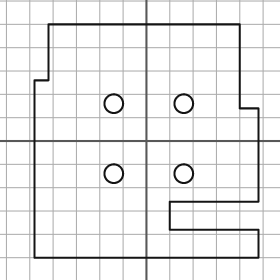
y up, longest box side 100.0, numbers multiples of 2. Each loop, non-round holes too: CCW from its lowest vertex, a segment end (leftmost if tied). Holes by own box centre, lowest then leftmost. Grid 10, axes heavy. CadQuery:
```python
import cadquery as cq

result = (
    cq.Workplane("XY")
    .moveTo(-48.0, -50.0)
    .lineTo(48.0, -50.0)
    .lineTo(48.0, -38.0)
    .lineTo(10.0, -38.0)
    .lineTo(10.0, -26.0)
    .lineTo(48.0, -26.0)
    .lineTo(48.0, 14.0)
    .lineTo(40.0, 14.0)
    .lineTo(40.0, 50.0)
    .lineTo(-42.0, 50.0)
    .lineTo(-42.0, 26.0)
    .lineTo(-48.0, 26.0)
    .close()
    .moveTo(-14.0, -14.0)
    .circle(4.0)
    .moveTo(16.0, -14.0)
    .circle(4.0)
    .moveTo(-14.0, 16.0)
    .circle(4.0)
    .moveTo(16.0, 16.0)
    .circle(4.0)
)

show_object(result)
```